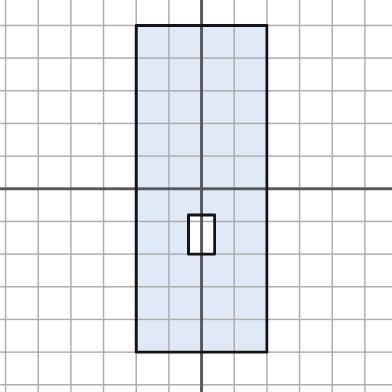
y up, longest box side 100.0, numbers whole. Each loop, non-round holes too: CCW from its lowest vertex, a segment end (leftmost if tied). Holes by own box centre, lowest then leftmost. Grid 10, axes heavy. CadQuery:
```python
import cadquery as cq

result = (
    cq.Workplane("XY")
    .moveTo(-20.0, -50.0)
    .lineTo(20.0, -50.0)
    .lineTo(20.0, 50.0)
    .lineTo(-20.0, 50.0)
    .close()
    .moveTo(-4.0, -20.0)
    .lineTo(4.0, -20.0)
    .lineTo(4.0, -8.0)
    .lineTo(-4.0, -8.0)
    .close()
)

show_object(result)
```